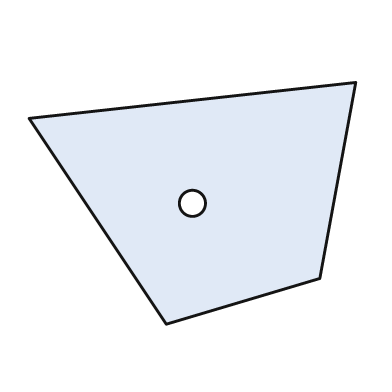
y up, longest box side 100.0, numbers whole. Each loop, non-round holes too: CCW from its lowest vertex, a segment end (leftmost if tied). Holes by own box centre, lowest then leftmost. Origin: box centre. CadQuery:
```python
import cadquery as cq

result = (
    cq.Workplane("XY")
    .moveTo(-8.0, -37.0)
    .lineTo(39.0, -23.0)
    .lineTo(50.0, 37.0)
    .lineTo(-50.0, 26.0)
    .close()
    .moveTo(0.0, 0.0)
    .circle(4.0)
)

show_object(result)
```